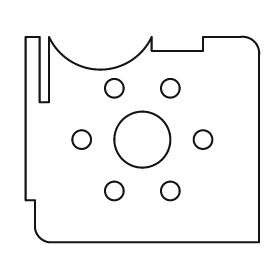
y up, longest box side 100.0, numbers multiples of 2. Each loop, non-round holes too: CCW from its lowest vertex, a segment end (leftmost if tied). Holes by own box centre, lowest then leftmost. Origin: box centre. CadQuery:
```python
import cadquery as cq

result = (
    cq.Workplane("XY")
    .moveTo(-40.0, -44.0)
    .lineTo(50.0, -44.0)
    .lineTo(50.0, 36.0)
    .threePointArc((48.0, 42.0), (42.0, 44.0))
    .lineTo(26.0, 44.0)
    .lineTo(26.0, 38.0)
    .lineTo(4.0, 38.0)
    .lineTo(4.0, 44.0)
    .threePointArc((-18.0, 30.0), (-40.0, 44.0))
    .lineTo(-40.0, 16.0)
    .lineTo(-44.0, 16.0)
    .lineTo(-44.0, 44.0)
    .lineTo(-50.0, 44.0)
    .lineTo(-50.0, -26.0)
    .lineTo(-46.0, -26.0)
    .lineTo(-46.0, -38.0)
    .threePointArc((-44.0, -42.0), (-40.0, -44.0))
    .close()
    .moveTo(-12.0, -22.0)
    .circle(4.0)
    .moveTo(12.0, -22.0)
    .circle(4.0)
    .moveTo(-26.0, 0.0)
    .circle(4.0)
    .moveTo(0.0, 0.0)
    .circle(12.0)
    .moveTo(26.0, 0.0)
    .circle(4.0)
    .moveTo(-12.0, 22.0)
    .circle(4.0)
    .moveTo(12.0, 22.0)
    .circle(4.0)
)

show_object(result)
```